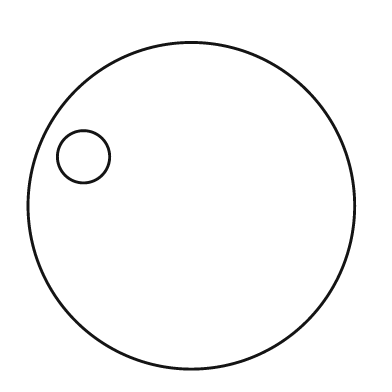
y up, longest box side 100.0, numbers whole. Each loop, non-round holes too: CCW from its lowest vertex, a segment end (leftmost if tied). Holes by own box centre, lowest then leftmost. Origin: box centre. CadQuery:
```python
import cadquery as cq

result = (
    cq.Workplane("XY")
    .moveTo(0.0, 0.0)
    .circle(50.0)
    .moveTo(-33.0, 15.0)
    .circle(8.0)
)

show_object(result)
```